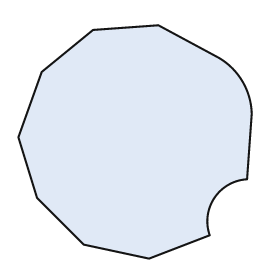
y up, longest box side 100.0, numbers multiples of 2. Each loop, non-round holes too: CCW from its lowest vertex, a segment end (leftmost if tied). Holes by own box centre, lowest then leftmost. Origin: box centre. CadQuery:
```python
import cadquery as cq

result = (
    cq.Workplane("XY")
    .moveTo(6.0, -50.0)
    .lineTo(32.0, -40.0)
    .threePointArc((34.0, -24.0), (48.0, -16.0))
    .lineTo(50.0, 12.0)
    .threePointArc((46.0, 26.0), (36.0, 36.0))
    .lineTo(10.0, 50.0)
    .lineTo(-18.0, 48.0)
    .lineTo(-40.0, 30.0)
    .lineTo(-50.0, 2.0)
    .lineTo(-42.0, -24.0)
    .lineTo(-22.0, -44.0)
    .close()
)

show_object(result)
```